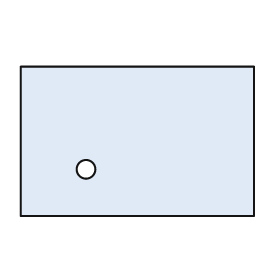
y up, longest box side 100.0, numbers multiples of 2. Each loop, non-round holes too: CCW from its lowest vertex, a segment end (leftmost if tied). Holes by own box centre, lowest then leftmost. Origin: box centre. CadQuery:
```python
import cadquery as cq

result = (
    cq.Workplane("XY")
    .moveTo(-50.0, -32.0)
    .lineTo(50.0, -32.0)
    .lineTo(50.0, 32.0)
    .lineTo(-50.0, 32.0)
    .close()
    .moveTo(-22.0, -12.0)
    .circle(4.0)
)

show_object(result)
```